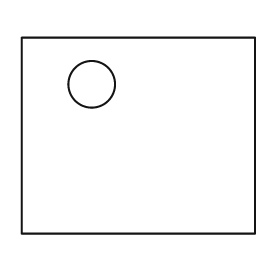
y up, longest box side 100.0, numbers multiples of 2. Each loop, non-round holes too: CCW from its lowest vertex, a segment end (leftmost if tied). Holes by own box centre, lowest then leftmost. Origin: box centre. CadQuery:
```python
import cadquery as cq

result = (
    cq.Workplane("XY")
    .moveTo(-50.0, -42.0)
    .lineTo(50.0, -42.0)
    .lineTo(50.0, 42.0)
    .lineTo(-50.0, 42.0)
    .close()
    .moveTo(-20.0, 22.0)
    .circle(10.0)
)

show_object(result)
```